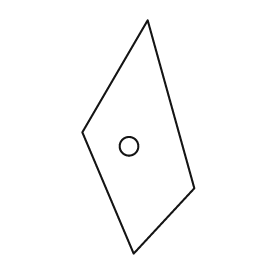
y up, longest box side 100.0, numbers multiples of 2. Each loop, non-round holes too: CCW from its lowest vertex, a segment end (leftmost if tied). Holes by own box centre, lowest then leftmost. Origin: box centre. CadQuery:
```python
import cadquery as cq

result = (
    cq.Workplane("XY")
    .moveTo(-2.0, -50.0)
    .lineTo(24.0, -22.0)
    .lineTo(4.0, 50.0)
    .lineTo(-24.0, 2.0)
    .close()
    .moveTo(-4.0, -4.0)
    .circle(4.0)
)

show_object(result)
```